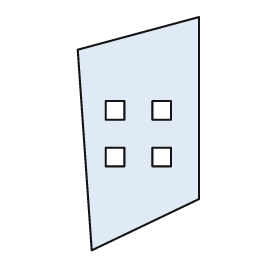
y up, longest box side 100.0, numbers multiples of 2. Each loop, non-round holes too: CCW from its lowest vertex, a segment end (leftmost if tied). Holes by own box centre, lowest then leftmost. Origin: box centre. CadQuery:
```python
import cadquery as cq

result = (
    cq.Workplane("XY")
    .moveTo(-20.0, -50.0)
    .lineTo(26.0, -28.0)
    .lineTo(26.0, 50.0)
    .lineTo(-26.0, 36.0)
    .close()
    .moveTo(-14.0, -14.0)
    .lineTo(-6.0, -14.0)
    .lineTo(-6.0, -6.0)
    .lineTo(-14.0, -6.0)
    .close()
    .moveTo(6.0, -14.0)
    .lineTo(14.0, -14.0)
    .lineTo(14.0, -6.0)
    .lineTo(6.0, -6.0)
    .close()
    .moveTo(-14.0, 6.0)
    .lineTo(-6.0, 6.0)
    .lineTo(-6.0, 14.0)
    .lineTo(-14.0, 14.0)
    .close()
    .moveTo(6.0, 6.0)
    .lineTo(14.0, 6.0)
    .lineTo(14.0, 14.0)
    .lineTo(6.0, 14.0)
    .close()
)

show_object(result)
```